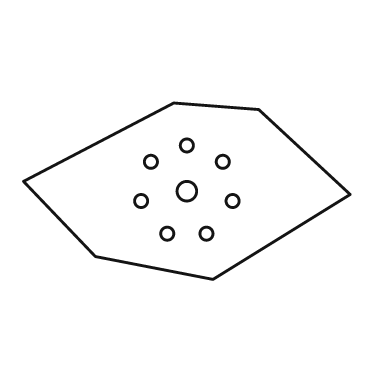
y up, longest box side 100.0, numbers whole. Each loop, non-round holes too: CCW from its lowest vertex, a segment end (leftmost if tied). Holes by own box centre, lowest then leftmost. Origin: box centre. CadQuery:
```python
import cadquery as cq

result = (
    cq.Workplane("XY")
    .moveTo(8.0, -27.0)
    .lineTo(50.0, -1.0)
    .lineTo(22.0, 25.0)
    .lineTo(-4.0, 27.0)
    .lineTo(-50.0, 3.0)
    .lineTo(-28.0, -20.0)
    .close()
    .moveTo(-6.0, -13.0)
    .circle(2.0)
    .moveTo(6.0, -13.0)
    .circle(2.0)
    .moveTo(-14.0, -3.0)
    .circle(2.0)
    .moveTo(14.0, -3.0)
    .circle(2.0)
    .moveTo(0.0, 0.0)
    .circle(3.0)
    .moveTo(-11.0, 9.0)
    .circle(2.0)
    .moveTo(11.0, 9.0)
    .circle(2.0)
    .moveTo(0.0, 14.0)
    .circle(2.0)
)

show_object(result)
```